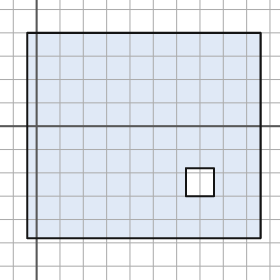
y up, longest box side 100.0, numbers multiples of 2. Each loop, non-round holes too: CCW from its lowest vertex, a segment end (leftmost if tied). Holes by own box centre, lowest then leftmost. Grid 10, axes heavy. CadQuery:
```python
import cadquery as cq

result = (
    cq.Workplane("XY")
    .moveTo(-4.0, -48.0)
    .lineTo(96.0, -48.0)
    .lineTo(96.0, 40.0)
    .lineTo(-4.0, 40.0)
    .close()
    .moveTo(64.0, -30.0)
    .lineTo(76.0, -30.0)
    .lineTo(76.0, -18.0)
    .lineTo(64.0, -18.0)
    .close()
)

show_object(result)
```